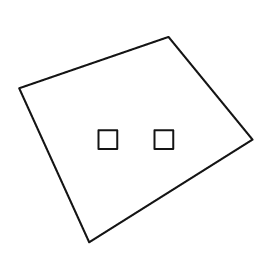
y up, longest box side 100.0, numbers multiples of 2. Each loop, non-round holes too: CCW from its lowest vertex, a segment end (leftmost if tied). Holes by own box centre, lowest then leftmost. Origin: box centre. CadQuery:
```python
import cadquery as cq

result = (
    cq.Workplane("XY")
    .moveTo(-20.0, -44.0)
    .lineTo(50.0, 0.0)
    .lineTo(14.0, 44.0)
    .lineTo(-50.0, 22.0)
    .close()
    .moveTo(-16.0, -4.0)
    .lineTo(-8.0, -4.0)
    .lineTo(-8.0, 4.0)
    .lineTo(-16.0, 4.0)
    .close()
    .moveTo(8.0, -4.0)
    .lineTo(16.0, -4.0)
    .lineTo(16.0, 4.0)
    .lineTo(8.0, 4.0)
    .close()
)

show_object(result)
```